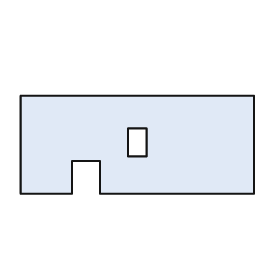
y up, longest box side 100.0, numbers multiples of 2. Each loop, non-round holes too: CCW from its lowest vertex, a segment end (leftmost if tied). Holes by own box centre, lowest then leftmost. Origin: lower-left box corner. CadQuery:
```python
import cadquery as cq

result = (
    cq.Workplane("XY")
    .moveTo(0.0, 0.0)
    .lineTo(22.0, 0.0)
    .lineTo(22.0, 14.0)
    .lineTo(34.0, 14.0)
    .lineTo(34.0, 0.0)
    .lineTo(100.0, 0.0)
    .lineTo(100.0, 42.0)
    .lineTo(0.0, 42.0)
    .close()
    .moveTo(46.0, 16.0)
    .lineTo(54.0, 16.0)
    .lineTo(54.0, 28.0)
    .lineTo(46.0, 28.0)
    .close()
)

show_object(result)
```